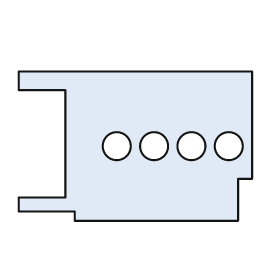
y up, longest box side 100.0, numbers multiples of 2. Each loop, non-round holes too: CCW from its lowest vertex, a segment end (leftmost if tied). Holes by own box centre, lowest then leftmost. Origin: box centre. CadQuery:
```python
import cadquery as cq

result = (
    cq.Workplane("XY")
    .moveTo(-26.0, -32.0)
    .lineTo(44.0, -32.0)
    .lineTo(44.0, -14.0)
    .lineTo(50.0, -14.0)
    .lineTo(50.0, 32.0)
    .lineTo(-50.0, 32.0)
    .lineTo(-50.0, 24.0)
    .lineTo(-30.0, 24.0)
    .lineTo(-30.0, -22.0)
    .lineTo(-50.0, -22.0)
    .lineTo(-50.0, -28.0)
    .lineTo(-26.0, -28.0)
    .close()
    .moveTo(-8.0, 0.0)
    .circle(6.0)
    .moveTo(8.0, 0.0)
    .circle(6.0)
    .moveTo(24.0, 0.0)
    .circle(6.0)
    .moveTo(40.0, 0.0)
    .circle(6.0)
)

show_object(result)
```